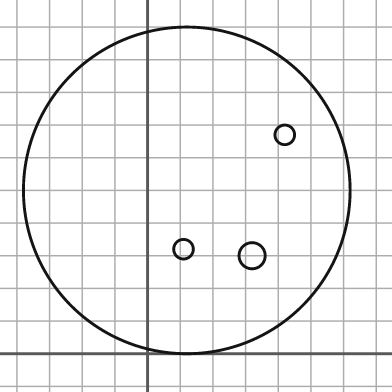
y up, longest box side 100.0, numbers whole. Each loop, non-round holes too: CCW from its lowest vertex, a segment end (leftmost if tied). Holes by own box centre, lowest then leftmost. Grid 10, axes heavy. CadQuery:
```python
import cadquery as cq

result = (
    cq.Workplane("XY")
    .moveTo(12.0, 50.0)
    .circle(50.0)
    .moveTo(32.0, 30.0)
    .circle(4.0)
    .moveTo(11.0, 32.0)
    .circle(3.0)
    .moveTo(42.0, 67.0)
    .circle(3.0)
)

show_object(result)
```